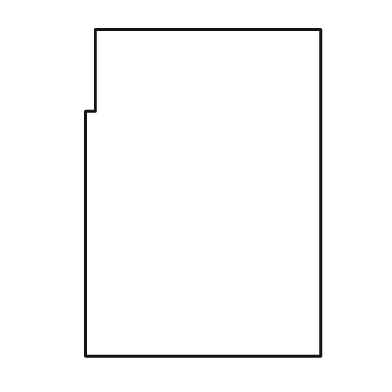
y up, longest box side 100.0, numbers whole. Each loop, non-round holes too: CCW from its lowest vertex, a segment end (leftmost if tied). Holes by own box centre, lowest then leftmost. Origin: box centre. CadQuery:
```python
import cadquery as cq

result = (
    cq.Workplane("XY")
    .moveTo(-36.0, -50.0)
    .lineTo(36.0, -50.0)
    .lineTo(36.0, 50.0)
    .lineTo(-33.0, 50.0)
    .lineTo(-33.0, 25.0)
    .lineTo(-36.0, 25.0)
    .close()
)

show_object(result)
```